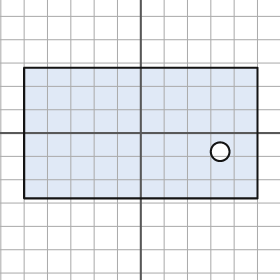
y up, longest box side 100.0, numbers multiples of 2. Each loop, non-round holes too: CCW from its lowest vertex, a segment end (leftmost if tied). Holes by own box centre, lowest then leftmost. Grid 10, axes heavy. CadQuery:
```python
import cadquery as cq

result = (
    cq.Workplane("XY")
    .moveTo(-50.0, -28.0)
    .lineTo(50.0, -28.0)
    .lineTo(50.0, 28.0)
    .lineTo(-50.0, 28.0)
    .close()
    .moveTo(34.0, -8.0)
    .circle(4.0)
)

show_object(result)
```